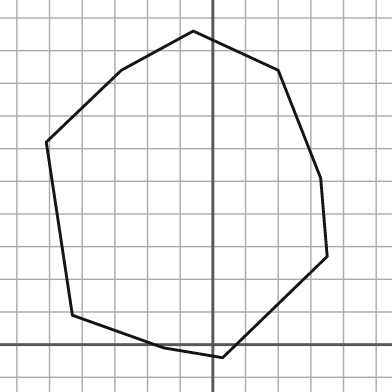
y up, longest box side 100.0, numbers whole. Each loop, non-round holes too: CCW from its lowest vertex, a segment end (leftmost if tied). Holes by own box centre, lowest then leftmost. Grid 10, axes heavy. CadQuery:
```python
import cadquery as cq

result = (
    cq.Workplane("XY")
    .moveTo(3.0, -4.0)
    .lineTo(35.0, 27.0)
    .lineTo(33.0, 51.0)
    .lineTo(20.0, 84.0)
    .lineTo(-6.0, 96.0)
    .lineTo(-28.0, 84.0)
    .lineTo(-51.0, 62.0)
    .lineTo(-43.0, 9.0)
    .lineTo(-15.0, -1.0)
    .close()
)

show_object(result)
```